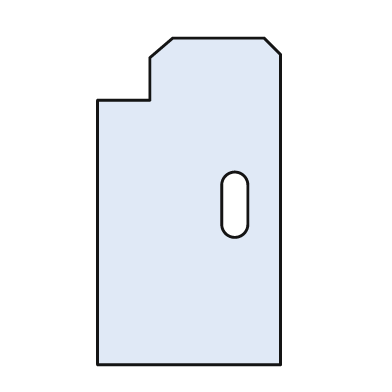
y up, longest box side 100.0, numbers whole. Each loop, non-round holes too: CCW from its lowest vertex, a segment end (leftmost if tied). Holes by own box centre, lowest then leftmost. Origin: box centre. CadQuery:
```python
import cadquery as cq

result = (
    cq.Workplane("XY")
    .moveTo(-28.0, -50.0)
    .lineTo(28.0, -50.0)
    .lineTo(28.0, 45.0)
    .lineTo(23.0, 50.0)
    .lineTo(-5.0, 50.0)
    .lineTo(-12.0, 44.0)
    .lineTo(-12.0, 31.0)
    .lineTo(-28.0, 31.0)
    .close()
    .moveTo(10.0, -7.0)
    .threePointArc((14.0, -11.0), (18.0, -7.0))
    .lineTo(18.0, 5.0)
    .threePointArc((14.0, 9.0), (10.0, 5.0))
    .close()
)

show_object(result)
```